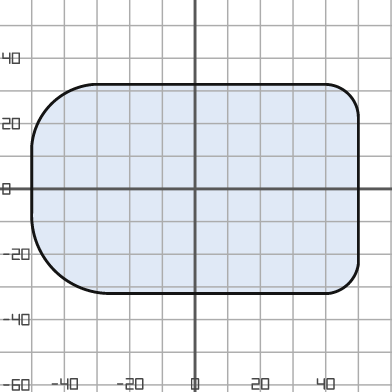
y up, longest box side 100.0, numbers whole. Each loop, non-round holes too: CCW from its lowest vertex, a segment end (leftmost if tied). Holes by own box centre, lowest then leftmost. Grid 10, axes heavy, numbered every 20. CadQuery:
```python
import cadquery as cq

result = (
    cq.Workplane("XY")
    .moveTo(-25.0, -32.0)
    .lineTo(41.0, -32.0)
    .threePointArc((47.0, -29.0), (50.0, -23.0))
    .lineTo(50.0, 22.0)
    .threePointArc((47.0, 29.0), (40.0, 32.0))
    .lineTo(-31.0, 32.0)
    .threePointArc((-44.0, 26.0), (-50.0, 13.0))
    .lineTo(-50.0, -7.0)
    .threePointArc((-43.0, -25.0), (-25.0, -32.0))
    .close()
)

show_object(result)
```